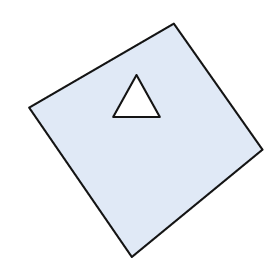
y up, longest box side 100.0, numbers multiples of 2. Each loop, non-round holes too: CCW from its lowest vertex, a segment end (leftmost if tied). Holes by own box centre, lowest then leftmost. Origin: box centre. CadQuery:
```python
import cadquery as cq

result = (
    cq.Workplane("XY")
    .moveTo(-6.0, -50.0)
    .lineTo(50.0, -4.0)
    .lineTo(12.0, 50.0)
    .lineTo(-50.0, 14.0)
    .close()
    .moveTo(-14.0, 10.0)
    .lineTo(6.0, 10.0)
    .lineTo(-4.0, 28.0)
    .close()
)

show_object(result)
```